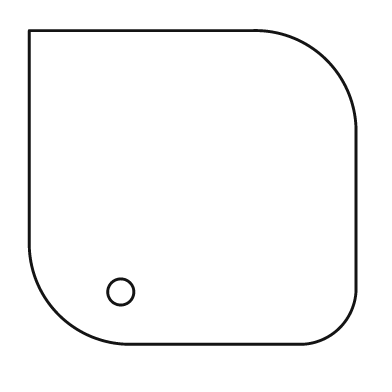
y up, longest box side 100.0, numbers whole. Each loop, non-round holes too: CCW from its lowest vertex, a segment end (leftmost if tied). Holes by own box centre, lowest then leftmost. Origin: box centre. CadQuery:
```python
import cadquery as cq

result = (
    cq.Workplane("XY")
    .moveTo(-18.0, -48.0)
    .lineTo(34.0, -48.0)
    .threePointArc((45.0, -43.0), (50.0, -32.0))
    .lineTo(50.0, 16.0)
    .threePointArc((41.0, 39.0), (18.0, 48.0))
    .lineTo(-50.0, 48.0)
    .lineTo(-50.0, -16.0)
    .threePointArc((-41.0, -39.0), (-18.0, -48.0))
    .close()
    .moveTo(-22.0, -32.0)
    .circle(4.0)
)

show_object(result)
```